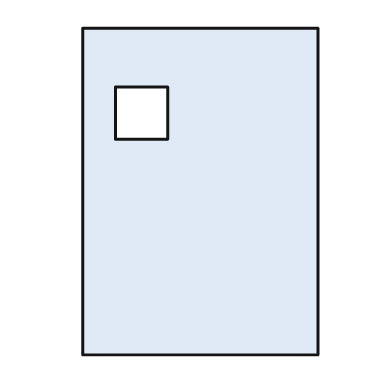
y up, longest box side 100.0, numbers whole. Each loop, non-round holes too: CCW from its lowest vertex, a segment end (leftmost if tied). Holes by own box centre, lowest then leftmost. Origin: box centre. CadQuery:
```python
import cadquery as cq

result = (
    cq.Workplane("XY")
    .moveTo(-36.0, -50.0)
    .lineTo(36.0, -50.0)
    .lineTo(36.0, 50.0)
    .lineTo(-36.0, 50.0)
    .close()
    .moveTo(-26.0, 16.0)
    .lineTo(-10.0, 16.0)
    .lineTo(-10.0, 32.0)
    .lineTo(-26.0, 32.0)
    .close()
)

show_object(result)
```